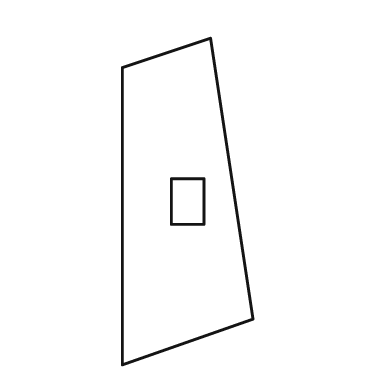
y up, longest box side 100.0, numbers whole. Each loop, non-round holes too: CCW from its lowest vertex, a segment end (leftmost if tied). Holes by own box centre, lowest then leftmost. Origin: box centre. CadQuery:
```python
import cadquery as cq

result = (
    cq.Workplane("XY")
    .moveTo(-20.0, -50.0)
    .lineTo(20.0, -36.0)
    .lineTo(7.0, 50.0)
    .lineTo(-20.0, 41.0)
    .close()
    .moveTo(-5.0, -7.0)
    .lineTo(5.0, -7.0)
    .lineTo(5.0, 7.0)
    .lineTo(-5.0, 7.0)
    .close()
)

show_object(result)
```